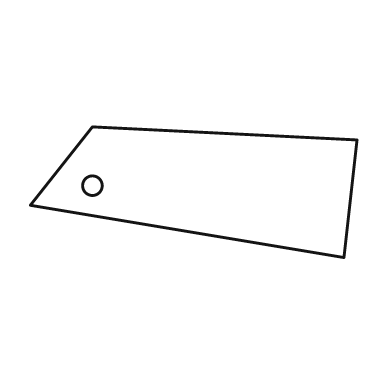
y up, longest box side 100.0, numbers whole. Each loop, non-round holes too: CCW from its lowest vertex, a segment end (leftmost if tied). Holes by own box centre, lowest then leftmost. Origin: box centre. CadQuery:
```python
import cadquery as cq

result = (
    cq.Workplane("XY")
    .moveTo(46.0, -20.0)
    .lineTo(50.0, 16.0)
    .lineTo(-31.0, 20.0)
    .lineTo(-50.0, -4.0)
    .close()
    .moveTo(-31.0, 2.0)
    .circle(3.0)
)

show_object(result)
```